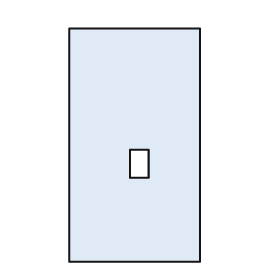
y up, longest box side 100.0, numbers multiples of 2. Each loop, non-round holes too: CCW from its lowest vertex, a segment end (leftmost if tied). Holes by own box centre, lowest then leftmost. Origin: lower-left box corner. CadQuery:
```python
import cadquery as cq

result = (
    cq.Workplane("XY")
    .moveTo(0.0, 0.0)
    .lineTo(56.0, 0.0)
    .lineTo(56.0, 100.0)
    .lineTo(0.0, 100.0)
    .close()
    .moveTo(26.0, 36.0)
    .lineTo(34.0, 36.0)
    .lineTo(34.0, 48.0)
    .lineTo(26.0, 48.0)
    .close()
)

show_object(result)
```